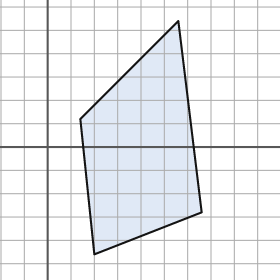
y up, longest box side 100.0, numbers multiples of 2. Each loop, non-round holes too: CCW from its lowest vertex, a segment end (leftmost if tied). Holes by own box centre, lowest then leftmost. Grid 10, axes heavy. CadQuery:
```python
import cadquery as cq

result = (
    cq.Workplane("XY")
    .moveTo(20.0, -46.0)
    .lineTo(66.0, -28.0)
    .lineTo(56.0, 54.0)
    .lineTo(14.0, 12.0)
    .close()
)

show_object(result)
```